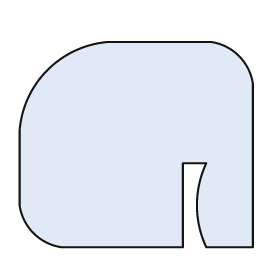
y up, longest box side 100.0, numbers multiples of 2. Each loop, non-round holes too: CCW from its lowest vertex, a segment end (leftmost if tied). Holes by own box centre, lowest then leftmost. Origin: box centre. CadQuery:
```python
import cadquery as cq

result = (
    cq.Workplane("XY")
    .moveTo(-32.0, -44.0)
    .lineTo(20.0, -44.0)
    .lineTo(20.0, -8.0)
    .lineTo(30.0, -8.0)
    .threePointArc((26.0, -26.0), (30.0, -44.0))
    .lineTo(50.0, -44.0)
    .lineTo(50.0, 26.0)
    .threePointArc((44.0, 38.0), (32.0, 44.0))
    .lineTo(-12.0, 44.0)
    .threePointArc((-38.0, 32.0), (-50.0, 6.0))
    .lineTo(-50.0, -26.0)
    .threePointArc((-44.0, -38.0), (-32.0, -44.0))
    .close()
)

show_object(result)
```